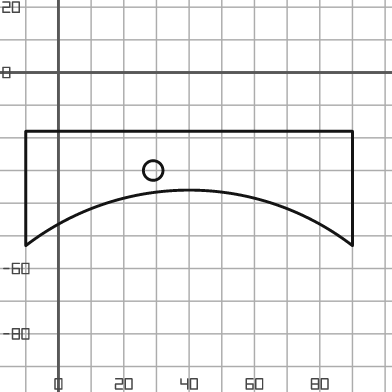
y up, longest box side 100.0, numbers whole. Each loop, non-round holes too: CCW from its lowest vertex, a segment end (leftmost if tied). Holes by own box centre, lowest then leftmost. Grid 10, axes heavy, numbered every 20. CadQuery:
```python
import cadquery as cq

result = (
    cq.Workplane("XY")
    .moveTo(-10.0, -53.0)
    .threePointArc((40.0, -36.0), (90.0, -53.0))
    .lineTo(90.0, -18.0)
    .lineTo(-10.0, -18.0)
    .close()
    .moveTo(29.0, -30.0)
    .circle(3.0)
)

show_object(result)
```